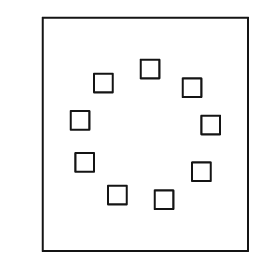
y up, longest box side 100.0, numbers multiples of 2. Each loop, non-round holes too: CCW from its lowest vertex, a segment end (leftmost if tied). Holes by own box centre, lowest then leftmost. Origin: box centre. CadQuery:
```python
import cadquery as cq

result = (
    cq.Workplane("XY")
    .moveTo(-44.0, -50.0)
    .lineTo(44.0, -50.0)
    .lineTo(44.0, 50.0)
    .lineTo(-44.0, 50.0)
    .close()
    .moveTo(4.0, -32.0)
    .lineTo(12.0, -32.0)
    .lineTo(12.0, -24.0)
    .lineTo(4.0, -24.0)
    .close()
    .moveTo(-16.0, -30.0)
    .lineTo(-8.0, -30.0)
    .lineTo(-8.0, -22.0)
    .lineTo(-16.0, -22.0)
    .close()
    .moveTo(20.0, -20.0)
    .lineTo(28.0, -20.0)
    .lineTo(28.0, -12.0)
    .lineTo(20.0, -12.0)
    .close()
    .moveTo(-30.0, -16.0)
    .lineTo(-22.0, -16.0)
    .lineTo(-22.0, -8.0)
    .lineTo(-30.0, -8.0)
    .close()
    .moveTo(24.0, 0.0)
    .lineTo(32.0, 0.0)
    .lineTo(32.0, 8.0)
    .lineTo(24.0, 8.0)
    .close()
    .moveTo(-32.0, 2.0)
    .lineTo(-24.0, 2.0)
    .lineTo(-24.0, 10.0)
    .lineTo(-32.0, 10.0)
    .close()
    .moveTo(16.0, 16.0)
    .lineTo(24.0, 16.0)
    .lineTo(24.0, 24.0)
    .lineTo(16.0, 24.0)
    .close()
    .moveTo(-22.0, 18.0)
    .lineTo(-14.0, 18.0)
    .lineTo(-14.0, 26.0)
    .lineTo(-22.0, 26.0)
    .close()
    .moveTo(-2.0, 24.0)
    .lineTo(6.0, 24.0)
    .lineTo(6.0, 32.0)
    .lineTo(-2.0, 32.0)
    .close()
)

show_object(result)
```